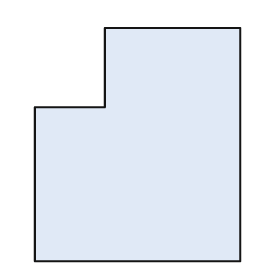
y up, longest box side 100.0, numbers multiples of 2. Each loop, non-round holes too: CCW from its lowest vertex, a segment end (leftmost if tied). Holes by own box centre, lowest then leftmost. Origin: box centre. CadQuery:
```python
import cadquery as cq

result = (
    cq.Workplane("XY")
    .moveTo(-44.0, -50.0)
    .lineTo(44.0, -50.0)
    .lineTo(44.0, 50.0)
    .lineTo(-14.0, 50.0)
    .lineTo(-14.0, 16.0)
    .lineTo(-44.0, 16.0)
    .close()
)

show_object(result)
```